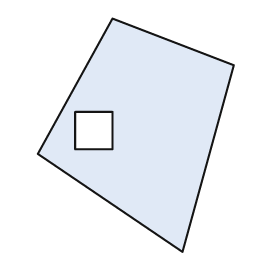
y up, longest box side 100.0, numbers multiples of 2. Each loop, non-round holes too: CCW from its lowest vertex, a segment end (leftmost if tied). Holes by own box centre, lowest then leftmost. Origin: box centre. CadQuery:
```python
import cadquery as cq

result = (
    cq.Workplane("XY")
    .moveTo(20.0, -50.0)
    .lineTo(42.0, 30.0)
    .lineTo(-10.0, 50.0)
    .lineTo(-42.0, -8.0)
    .close()
    .moveTo(-26.0, -6.0)
    .lineTo(-10.0, -6.0)
    .lineTo(-10.0, 10.0)
    .lineTo(-26.0, 10.0)
    .close()
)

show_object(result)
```